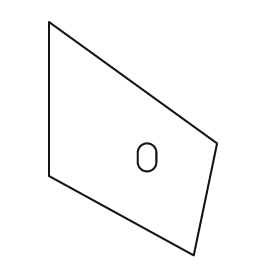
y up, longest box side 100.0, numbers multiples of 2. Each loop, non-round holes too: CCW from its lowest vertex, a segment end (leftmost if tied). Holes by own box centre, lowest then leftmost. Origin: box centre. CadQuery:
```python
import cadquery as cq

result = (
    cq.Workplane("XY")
    .moveTo(26.0, -50.0)
    .lineTo(36.0, -2.0)
    .lineTo(-36.0, 50.0)
    .lineTo(-36.0, -16.0)
    .close()
    .moveTo(2.0, -10.0)
    .threePointArc((6.0, -14.0), (10.0, -10.0))
    .lineTo(10.0, -6.0)
    .threePointArc((6.0, -2.0), (2.0, -6.0))
    .close()
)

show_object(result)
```